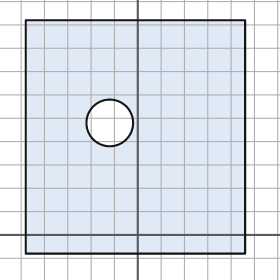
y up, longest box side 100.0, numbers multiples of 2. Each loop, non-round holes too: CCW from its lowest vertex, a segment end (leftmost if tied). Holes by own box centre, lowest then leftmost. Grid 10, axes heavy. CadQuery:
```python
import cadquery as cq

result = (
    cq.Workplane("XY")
    .moveTo(-48.0, -8.0)
    .lineTo(46.0, -8.0)
    .lineTo(46.0, 92.0)
    .lineTo(-48.0, 92.0)
    .close()
    .moveTo(-12.0, 48.0)
    .circle(10.0)
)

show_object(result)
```